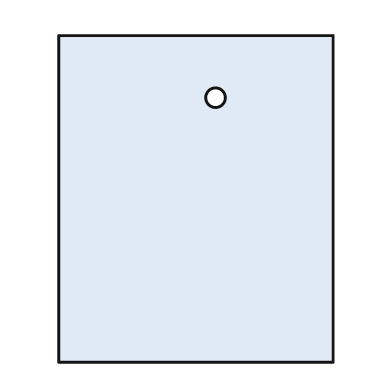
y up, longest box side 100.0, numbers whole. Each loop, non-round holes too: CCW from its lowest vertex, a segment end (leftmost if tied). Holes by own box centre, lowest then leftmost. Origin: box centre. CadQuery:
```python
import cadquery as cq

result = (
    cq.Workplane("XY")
    .moveTo(-42.0, -50.0)
    .lineTo(42.0, -50.0)
    .lineTo(42.0, 50.0)
    .lineTo(-42.0, 50.0)
    .close()
    .moveTo(6.0, 31.0)
    .circle(3.0)
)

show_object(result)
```